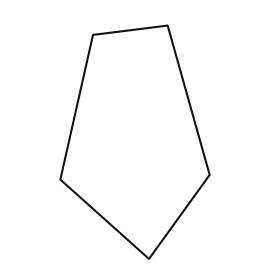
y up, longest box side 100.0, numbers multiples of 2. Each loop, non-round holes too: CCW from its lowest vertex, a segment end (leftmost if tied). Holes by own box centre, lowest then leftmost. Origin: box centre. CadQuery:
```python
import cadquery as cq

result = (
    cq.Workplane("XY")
    .moveTo(6.0, -50.0)
    .lineTo(32.0, -14.0)
    .lineTo(14.0, 50.0)
    .lineTo(-18.0, 46.0)
    .lineTo(-32.0, -16.0)
    .close()
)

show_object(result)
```